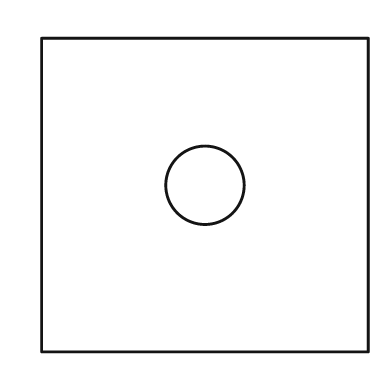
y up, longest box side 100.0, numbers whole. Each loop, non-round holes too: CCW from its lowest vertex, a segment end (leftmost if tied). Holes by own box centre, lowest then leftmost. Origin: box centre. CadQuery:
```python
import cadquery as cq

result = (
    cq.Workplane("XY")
    .moveTo(-50.0, -48.0)
    .lineTo(50.0, -48.0)
    .lineTo(50.0, 48.0)
    .lineTo(-50.0, 48.0)
    .close()
    .moveTo(0.0, 3.0)
    .circle(12.0)
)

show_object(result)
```